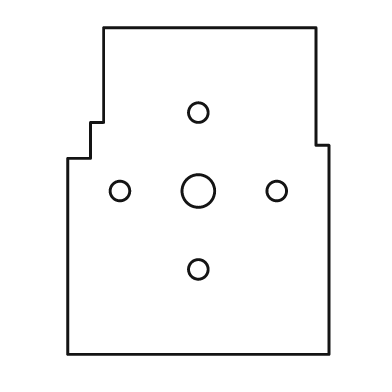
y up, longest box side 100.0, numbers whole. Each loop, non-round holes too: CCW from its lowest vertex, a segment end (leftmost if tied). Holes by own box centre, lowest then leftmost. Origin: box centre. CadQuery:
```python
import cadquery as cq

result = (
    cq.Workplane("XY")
    .moveTo(-40.0, -50.0)
    .lineTo(40.0, -50.0)
    .lineTo(40.0, 14.0)
    .lineTo(36.0, 14.0)
    .lineTo(36.0, 50.0)
    .lineTo(-29.0, 50.0)
    .lineTo(-29.0, 21.0)
    .lineTo(-33.0, 21.0)
    .lineTo(-33.0, 10.0)
    .lineTo(-40.0, 10.0)
    .close()
    .moveTo(0.0, -24.0)
    .circle(3.0)
    .moveTo(-24.0, 0.0)
    .circle(3.0)
    .moveTo(0.0, 0.0)
    .circle(5.0)
    .moveTo(24.0, 0.0)
    .circle(3.0)
    .moveTo(0.0, 24.0)
    .circle(3.0)
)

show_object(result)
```